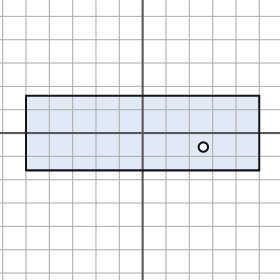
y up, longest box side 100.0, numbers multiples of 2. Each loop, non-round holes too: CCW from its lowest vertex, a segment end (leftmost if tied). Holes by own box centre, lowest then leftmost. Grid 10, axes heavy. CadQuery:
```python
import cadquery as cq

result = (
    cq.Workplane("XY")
    .moveTo(-50.0, -16.0)
    .lineTo(50.0, -16.0)
    .lineTo(50.0, 16.0)
    .lineTo(-50.0, 16.0)
    .close()
    .moveTo(26.0, -6.0)
    .circle(2.0)
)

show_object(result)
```